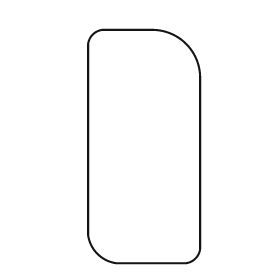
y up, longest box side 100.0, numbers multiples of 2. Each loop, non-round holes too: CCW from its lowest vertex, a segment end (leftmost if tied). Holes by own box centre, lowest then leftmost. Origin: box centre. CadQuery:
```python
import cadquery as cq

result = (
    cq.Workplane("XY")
    .moveTo(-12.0, -50.0)
    .lineTo(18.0, -50.0)
    .threePointArc((22.0, -48.0), (24.0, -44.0))
    .lineTo(24.0, 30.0)
    .threePointArc((18.0, 44.0), (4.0, 50.0))
    .lineTo(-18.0, 50.0)
    .threePointArc((-22.0, 48.0), (-24.0, 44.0))
    .lineTo(-24.0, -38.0)
    .threePointArc((-20.0, -46.0), (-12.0, -50.0))
    .close()
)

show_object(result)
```